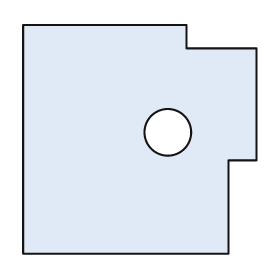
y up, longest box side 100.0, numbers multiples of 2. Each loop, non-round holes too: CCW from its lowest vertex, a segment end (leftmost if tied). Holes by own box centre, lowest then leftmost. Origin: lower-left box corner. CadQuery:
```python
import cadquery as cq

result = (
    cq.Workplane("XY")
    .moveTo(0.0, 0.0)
    .lineTo(88.0, 0.0)
    .lineTo(88.0, 40.0)
    .lineTo(100.0, 40.0)
    .lineTo(100.0, 88.0)
    .lineTo(70.0, 88.0)
    .lineTo(70.0, 98.0)
    .lineTo(0.0, 98.0)
    .close()
    .moveTo(62.0, 52.0)
    .circle(10.0)
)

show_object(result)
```